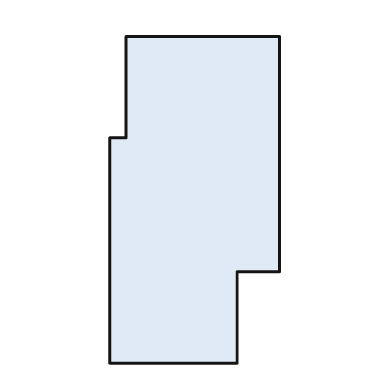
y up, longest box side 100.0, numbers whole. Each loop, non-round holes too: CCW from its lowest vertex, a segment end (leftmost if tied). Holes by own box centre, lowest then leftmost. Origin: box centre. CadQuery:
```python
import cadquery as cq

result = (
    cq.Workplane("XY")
    .moveTo(-26.0, -50.0)
    .lineTo(13.0, -50.0)
    .lineTo(13.0, -22.0)
    .lineTo(26.0, -22.0)
    .lineTo(26.0, 50.0)
    .lineTo(-21.0, 50.0)
    .lineTo(-21.0, 19.0)
    .lineTo(-26.0, 19.0)
    .close()
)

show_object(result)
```